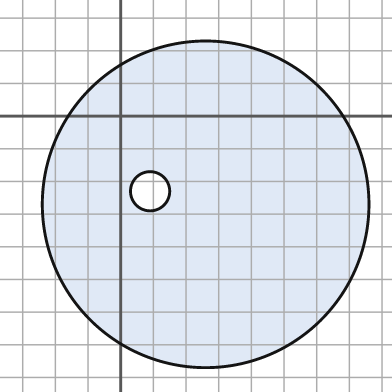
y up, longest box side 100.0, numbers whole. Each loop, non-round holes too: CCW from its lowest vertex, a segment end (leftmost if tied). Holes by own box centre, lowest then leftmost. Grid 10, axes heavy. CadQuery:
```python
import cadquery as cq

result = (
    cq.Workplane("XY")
    .moveTo(26.0, -27.0)
    .circle(50.0)
    .moveTo(9.0, -23.0)
    .circle(6.0)
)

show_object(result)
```